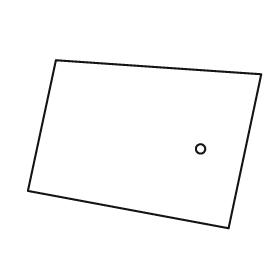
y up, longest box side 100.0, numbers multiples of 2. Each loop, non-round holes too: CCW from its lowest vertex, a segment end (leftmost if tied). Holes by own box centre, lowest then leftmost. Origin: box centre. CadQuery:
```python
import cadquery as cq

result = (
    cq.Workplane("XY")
    .moveTo(36.0, -36.0)
    .lineTo(50.0, 30.0)
    .lineTo(-38.0, 36.0)
    .lineTo(-50.0, -20.0)
    .close()
    .moveTo(24.0, -2.0)
    .circle(2.0)
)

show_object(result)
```